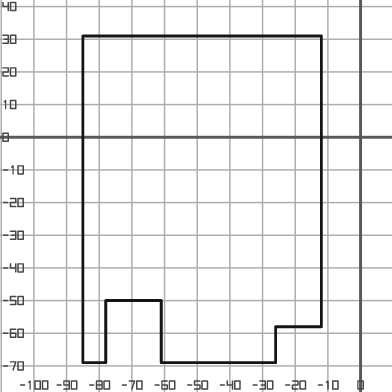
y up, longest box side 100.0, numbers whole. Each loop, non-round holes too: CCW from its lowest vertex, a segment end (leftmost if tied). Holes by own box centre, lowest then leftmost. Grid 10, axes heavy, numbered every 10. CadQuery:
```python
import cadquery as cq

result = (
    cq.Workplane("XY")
    .moveTo(-85.0, -69.0)
    .lineTo(-78.0, -69.0)
    .lineTo(-78.0, -50.0)
    .lineTo(-61.0, -50.0)
    .lineTo(-61.0, -69.0)
    .lineTo(-26.0, -69.0)
    .lineTo(-26.0, -58.0)
    .lineTo(-12.0, -58.0)
    .lineTo(-12.0, 31.0)
    .lineTo(-85.0, 31.0)
    .close()
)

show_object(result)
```